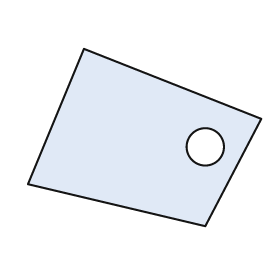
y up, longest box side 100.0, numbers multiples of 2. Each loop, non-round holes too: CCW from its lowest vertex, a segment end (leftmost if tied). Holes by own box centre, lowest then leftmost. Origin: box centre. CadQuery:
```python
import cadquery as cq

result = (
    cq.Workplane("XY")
    .moveTo(26.0, -38.0)
    .lineTo(50.0, 8.0)
    .lineTo(-26.0, 38.0)
    .lineTo(-50.0, -20.0)
    .close()
    .moveTo(26.0, -4.0)
    .circle(8.0)
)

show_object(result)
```